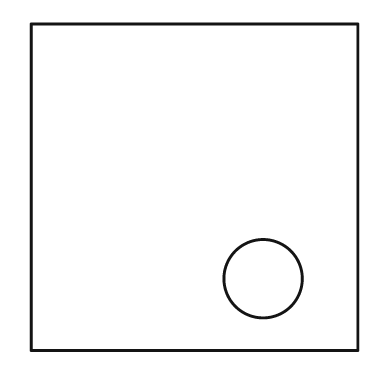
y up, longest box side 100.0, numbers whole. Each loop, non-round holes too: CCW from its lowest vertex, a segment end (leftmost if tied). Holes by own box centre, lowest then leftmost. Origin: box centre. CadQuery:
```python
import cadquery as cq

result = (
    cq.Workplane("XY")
    .moveTo(-50.0, -50.0)
    .lineTo(50.0, -50.0)
    .lineTo(50.0, 50.0)
    .lineTo(-50.0, 50.0)
    .close()
    .moveTo(21.0, -28.0)
    .circle(12.0)
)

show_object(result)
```